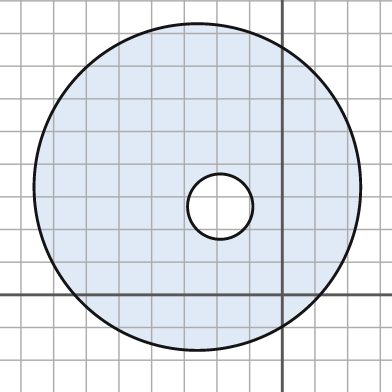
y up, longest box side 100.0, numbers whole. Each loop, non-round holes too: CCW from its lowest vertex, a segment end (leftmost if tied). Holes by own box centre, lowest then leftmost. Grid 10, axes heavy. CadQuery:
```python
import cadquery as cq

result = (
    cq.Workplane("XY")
    .moveTo(-26.0, 33.0)
    .circle(50.0)
    .moveTo(-19.0, 27.0)
    .circle(10.0)
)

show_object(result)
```